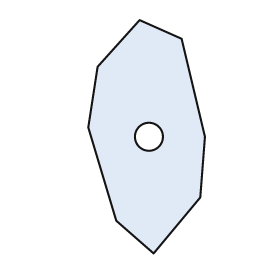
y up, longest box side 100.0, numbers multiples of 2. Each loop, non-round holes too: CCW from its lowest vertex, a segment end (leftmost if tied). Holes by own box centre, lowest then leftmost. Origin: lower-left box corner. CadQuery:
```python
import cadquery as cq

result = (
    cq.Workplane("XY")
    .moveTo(28.0, 0.0)
    .lineTo(48.0, 24.0)
    .lineTo(50.0, 50.0)
    .lineTo(40.0, 92.0)
    .lineTo(22.0, 100.0)
    .lineTo(4.0, 80.0)
    .lineTo(0.0, 54.0)
    .lineTo(12.0, 14.0)
    .close()
    .moveTo(26.0, 50.0)
    .circle(6.0)
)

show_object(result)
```